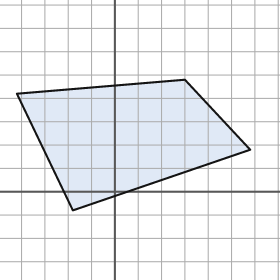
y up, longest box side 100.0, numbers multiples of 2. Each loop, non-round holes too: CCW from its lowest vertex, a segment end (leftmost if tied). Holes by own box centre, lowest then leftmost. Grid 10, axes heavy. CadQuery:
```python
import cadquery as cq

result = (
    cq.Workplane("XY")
    .moveTo(-18.0, -8.0)
    .lineTo(58.0, 18.0)
    .lineTo(30.0, 48.0)
    .lineTo(-42.0, 42.0)
    .close()
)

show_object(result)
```